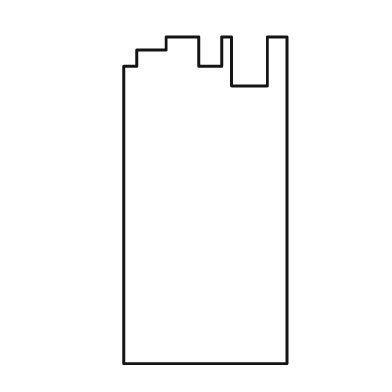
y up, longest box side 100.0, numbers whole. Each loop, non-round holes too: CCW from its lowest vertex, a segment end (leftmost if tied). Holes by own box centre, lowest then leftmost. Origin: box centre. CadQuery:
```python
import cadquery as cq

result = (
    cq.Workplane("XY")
    .moveTo(-25.0, -50.0)
    .lineTo(25.0, -50.0)
    .lineTo(25.0, 50.0)
    .lineTo(19.0, 50.0)
    .lineTo(19.0, 35.0)
    .lineTo(8.0, 35.0)
    .lineTo(8.0, 50.0)
    .lineTo(5.0, 50.0)
    .lineTo(5.0, 41.0)
    .lineTo(-2.0, 41.0)
    .lineTo(-2.0, 50.0)
    .lineTo(-12.0, 50.0)
    .lineTo(-12.0, 46.0)
    .lineTo(-21.0, 46.0)
    .lineTo(-21.0, 41.0)
    .lineTo(-25.0, 41.0)
    .close()
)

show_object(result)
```